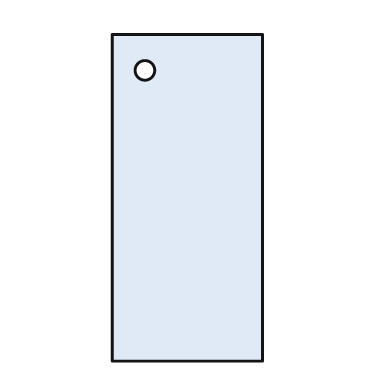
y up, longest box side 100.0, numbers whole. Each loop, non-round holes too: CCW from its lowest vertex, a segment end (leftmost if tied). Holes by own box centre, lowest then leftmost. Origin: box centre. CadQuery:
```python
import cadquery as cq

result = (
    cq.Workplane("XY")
    .moveTo(-23.0, -50.0)
    .lineTo(23.0, -50.0)
    .lineTo(23.0, 50.0)
    .lineTo(-23.0, 50.0)
    .close()
    .moveTo(-13.0, 39.0)
    .circle(3.0)
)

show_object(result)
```